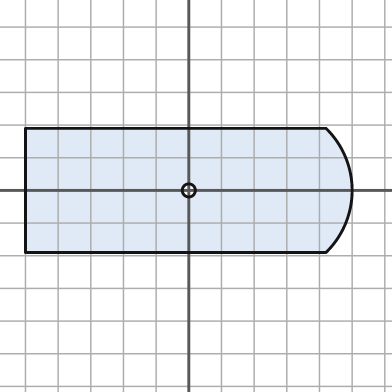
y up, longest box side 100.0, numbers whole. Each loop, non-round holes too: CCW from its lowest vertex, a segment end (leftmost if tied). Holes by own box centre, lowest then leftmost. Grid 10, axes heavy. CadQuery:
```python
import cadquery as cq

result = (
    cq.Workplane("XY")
    .moveTo(-50.0, -19.0)
    .lineTo(42.0, -19.0)
    .threePointArc((50.0, 0.0), (42.0, 19.0))
    .lineTo(-50.0, 19.0)
    .close()
    .moveTo(0.0, 0.0)
    .circle(2.0)
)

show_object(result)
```